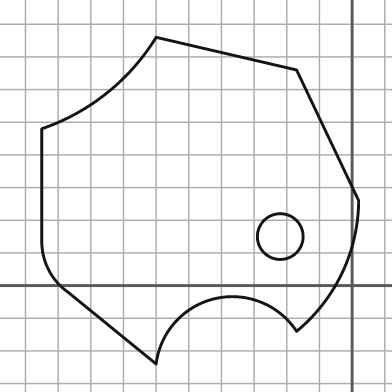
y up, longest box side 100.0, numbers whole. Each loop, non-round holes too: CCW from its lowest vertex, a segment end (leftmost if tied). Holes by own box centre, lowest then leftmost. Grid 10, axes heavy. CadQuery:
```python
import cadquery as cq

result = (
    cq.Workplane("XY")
    .moveTo(-60.0, -24.0)
    .threePointArc((-42.0, -4.0), (-17.0, -14.0))
    .threePointArc((-3.0, 4.0), (2.0, 26.0))
    .lineTo(-17.0, 66.0)
    .lineTo(-60.0, 76.0)
    .threePointArc((-75.0, 59.0), (-95.0, 48.0))
    .lineTo(-95.0, 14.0)
    .threePointArc((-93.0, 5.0), (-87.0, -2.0))
    .close()
    .moveTo(-22.0, 15.0)
    .circle(7.0)
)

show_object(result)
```